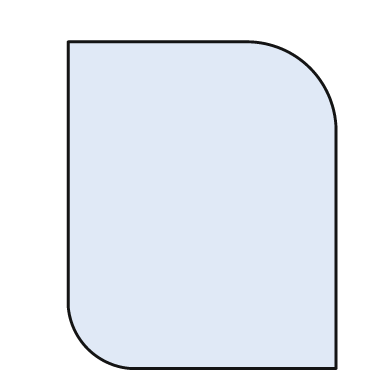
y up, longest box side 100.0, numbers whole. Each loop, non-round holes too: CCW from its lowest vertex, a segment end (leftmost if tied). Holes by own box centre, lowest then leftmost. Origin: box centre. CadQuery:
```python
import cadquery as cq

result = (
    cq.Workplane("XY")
    .moveTo(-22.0, -50.0)
    .lineTo(41.0, -50.0)
    .lineTo(41.0, 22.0)
    .threePointArc((33.0, 42.0), (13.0, 50.0))
    .lineTo(-41.0, 50.0)
    .lineTo(-41.0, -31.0)
    .threePointArc((-35.0, -44.0), (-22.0, -50.0))
    .close()
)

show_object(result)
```